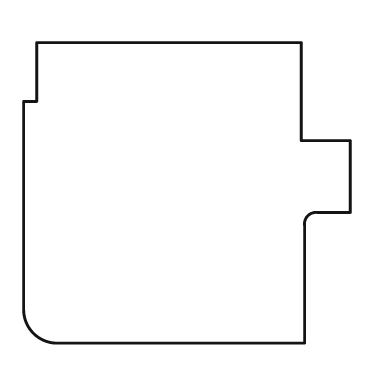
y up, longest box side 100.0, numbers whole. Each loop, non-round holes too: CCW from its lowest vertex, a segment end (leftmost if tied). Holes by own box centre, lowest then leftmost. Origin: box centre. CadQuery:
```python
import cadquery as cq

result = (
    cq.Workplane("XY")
    .moveTo(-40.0, -46.0)
    .lineTo(36.0, -46.0)
    .lineTo(36.0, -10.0)
    .threePointArc((37.0, -7.0), (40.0, -6.0))
    .lineTo(50.0, -6.0)
    .lineTo(50.0, 16.0)
    .lineTo(35.0, 16.0)
    .lineTo(35.0, 46.0)
    .lineTo(-46.0, 46.0)
    .lineTo(-46.0, 28.0)
    .lineTo(-50.0, 28.0)
    .lineTo(-50.0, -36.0)
    .threePointArc((-47.0, -43.0), (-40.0, -46.0))
    .close()
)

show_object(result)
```